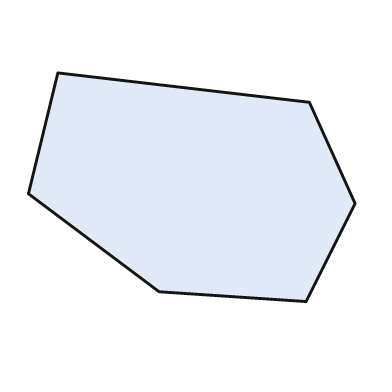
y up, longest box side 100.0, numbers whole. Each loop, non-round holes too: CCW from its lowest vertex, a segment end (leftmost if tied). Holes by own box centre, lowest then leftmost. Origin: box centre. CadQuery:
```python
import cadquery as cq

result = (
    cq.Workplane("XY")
    .moveTo(35.0, -35.0)
    .lineTo(50.0, -5.0)
    .lineTo(36.0, 26.0)
    .lineTo(-41.0, 35.0)
    .lineTo(-50.0, -2.0)
    .lineTo(-10.0, -32.0)
    .close()
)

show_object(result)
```